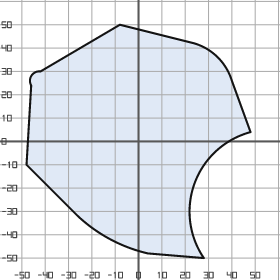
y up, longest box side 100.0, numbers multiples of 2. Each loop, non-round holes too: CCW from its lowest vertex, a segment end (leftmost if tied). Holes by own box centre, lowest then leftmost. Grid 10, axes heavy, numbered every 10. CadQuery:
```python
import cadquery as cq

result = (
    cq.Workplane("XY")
    .moveTo(28.0, -50.0)
    .threePointArc((24.0, -18.0), (48.0, 4.0))
    .lineTo(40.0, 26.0)
    .threePointArc((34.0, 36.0), (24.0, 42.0))
    .lineTo(-8.0, 50.0)
    .lineTo(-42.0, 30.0)
    .threePointArc((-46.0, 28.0), (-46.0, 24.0))
    .lineTo(-48.0, -10.0)
    .lineTo(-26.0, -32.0)
    .threePointArc((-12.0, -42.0), (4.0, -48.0))
    .close()
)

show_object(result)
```